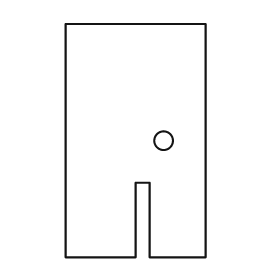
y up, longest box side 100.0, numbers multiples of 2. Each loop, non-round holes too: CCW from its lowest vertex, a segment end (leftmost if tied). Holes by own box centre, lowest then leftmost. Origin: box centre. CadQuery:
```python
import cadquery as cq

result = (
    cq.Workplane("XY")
    .moveTo(-30.0, -50.0)
    .lineTo(0.0, -50.0)
    .lineTo(0.0, -18.0)
    .lineTo(6.0, -18.0)
    .lineTo(6.0, -50.0)
    .lineTo(30.0, -50.0)
    .lineTo(30.0, 50.0)
    .lineTo(-30.0, 50.0)
    .close()
    .moveTo(12.0, 0.0)
    .circle(4.0)
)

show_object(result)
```